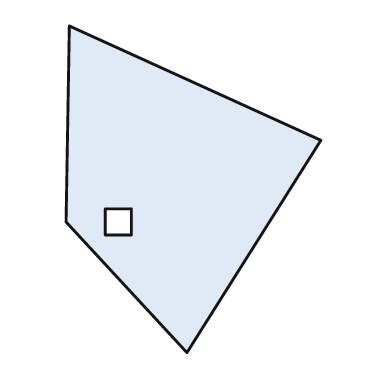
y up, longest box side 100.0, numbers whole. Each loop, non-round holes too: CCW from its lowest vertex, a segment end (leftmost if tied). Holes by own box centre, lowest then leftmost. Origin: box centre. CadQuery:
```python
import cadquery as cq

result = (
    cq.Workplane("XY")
    .moveTo(-2.0, -50.0)
    .lineTo(39.0, 15.0)
    .lineTo(-38.0, 50.0)
    .lineTo(-39.0, -10.0)
    .close()
    .moveTo(-27.0, -14.0)
    .lineTo(-19.0, -14.0)
    .lineTo(-19.0, -6.0)
    .lineTo(-27.0, -6.0)
    .close()
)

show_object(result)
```